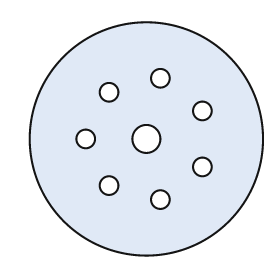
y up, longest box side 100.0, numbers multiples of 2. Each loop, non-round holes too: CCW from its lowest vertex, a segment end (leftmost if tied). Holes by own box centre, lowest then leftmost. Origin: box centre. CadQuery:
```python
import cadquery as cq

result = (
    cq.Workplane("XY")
    .moveTo(0.0, 0.0)
    .circle(50.0)
    .moveTo(6.0, -26.0)
    .circle(4.0)
    .moveTo(-16.0, -20.0)
    .circle(4.0)
    .moveTo(24.0, -12.0)
    .circle(4.0)
    .moveTo(-26.0, 0.0)
    .circle(4.0)
    .moveTo(0.0, 0.0)
    .circle(6.0)
    .moveTo(24.0, 12.0)
    .circle(4.0)
    .moveTo(-16.0, 20.0)
    .circle(4.0)
    .moveTo(6.0, 26.0)
    .circle(4.0)
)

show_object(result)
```